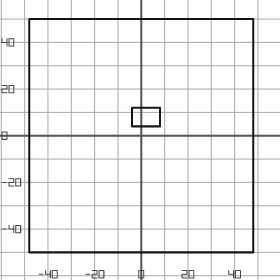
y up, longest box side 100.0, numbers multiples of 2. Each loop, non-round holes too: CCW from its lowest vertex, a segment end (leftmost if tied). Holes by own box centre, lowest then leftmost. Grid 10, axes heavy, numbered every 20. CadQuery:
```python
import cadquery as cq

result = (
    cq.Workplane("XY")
    .moveTo(-48.0, -50.0)
    .lineTo(48.0, -50.0)
    .lineTo(48.0, 50.0)
    .lineTo(-48.0, 50.0)
    .close()
    .moveTo(-4.0, 4.0)
    .lineTo(8.0, 4.0)
    .lineTo(8.0, 12.0)
    .lineTo(-4.0, 12.0)
    .close()
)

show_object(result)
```